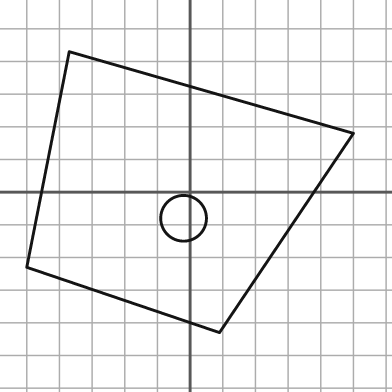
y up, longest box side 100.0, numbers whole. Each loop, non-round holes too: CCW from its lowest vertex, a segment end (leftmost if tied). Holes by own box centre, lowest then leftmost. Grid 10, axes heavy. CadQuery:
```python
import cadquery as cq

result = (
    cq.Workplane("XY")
    .moveTo(9.0, -43.0)
    .lineTo(50.0, 18.0)
    .lineTo(-37.0, 43.0)
    .lineTo(-50.0, -23.0)
    .close()
    .moveTo(-2.0, -8.0)
    .circle(7.0)
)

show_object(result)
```